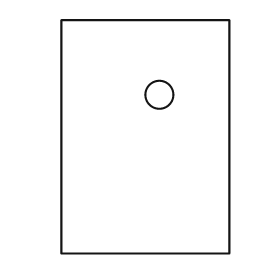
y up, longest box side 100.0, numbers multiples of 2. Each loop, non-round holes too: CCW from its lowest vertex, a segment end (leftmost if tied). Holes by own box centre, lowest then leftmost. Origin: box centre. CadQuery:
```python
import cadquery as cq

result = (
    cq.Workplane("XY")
    .moveTo(-36.0, -50.0)
    .lineTo(36.0, -50.0)
    .lineTo(36.0, 50.0)
    .lineTo(-36.0, 50.0)
    .close()
    .moveTo(6.0, 18.0)
    .circle(6.0)
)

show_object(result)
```